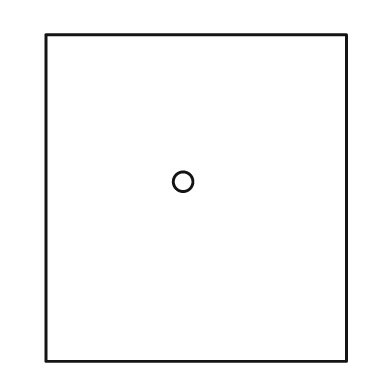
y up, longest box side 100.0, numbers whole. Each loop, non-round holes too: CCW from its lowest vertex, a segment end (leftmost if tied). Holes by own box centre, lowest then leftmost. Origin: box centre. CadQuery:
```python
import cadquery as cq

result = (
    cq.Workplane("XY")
    .moveTo(-46.0, -50.0)
    .lineTo(46.0, -50.0)
    .lineTo(46.0, 50.0)
    .lineTo(-46.0, 50.0)
    .close()
    .moveTo(-4.0, 5.0)
    .circle(3.0)
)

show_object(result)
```